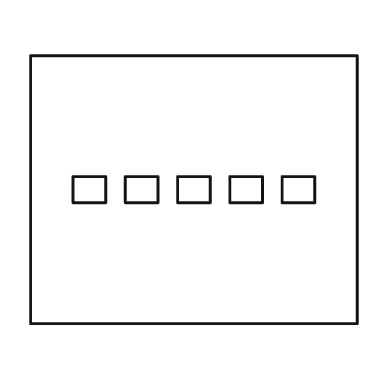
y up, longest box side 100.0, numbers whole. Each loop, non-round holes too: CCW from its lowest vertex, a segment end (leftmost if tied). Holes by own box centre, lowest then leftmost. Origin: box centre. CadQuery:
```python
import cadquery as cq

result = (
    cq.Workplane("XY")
    .moveTo(-50.0, -41.0)
    .lineTo(50.0, -41.0)
    .lineTo(50.0, 41.0)
    .lineTo(-50.0, 41.0)
    .close()
    .moveTo(-37.0, -4.0)
    .lineTo(-27.0, -4.0)
    .lineTo(-27.0, 4.0)
    .lineTo(-37.0, 4.0)
    .close()
    .moveTo(-21.0, -4.0)
    .lineTo(-11.0, -4.0)
    .lineTo(-11.0, 4.0)
    .lineTo(-21.0, 4.0)
    .close()
    .moveTo(-5.0, -4.0)
    .lineTo(5.0, -4.0)
    .lineTo(5.0, 4.0)
    .lineTo(-5.0, 4.0)
    .close()
    .moveTo(11.0, -4.0)
    .lineTo(21.0, -4.0)
    .lineTo(21.0, 4.0)
    .lineTo(11.0, 4.0)
    .close()
    .moveTo(27.0, -4.0)
    .lineTo(37.0, -4.0)
    .lineTo(37.0, 4.0)
    .lineTo(27.0, 4.0)
    .close()
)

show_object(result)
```